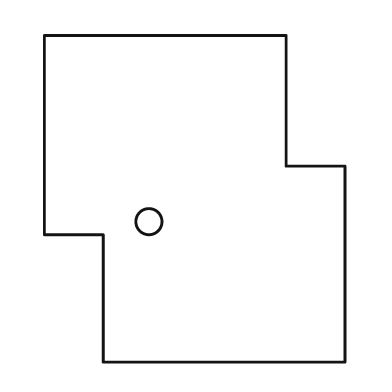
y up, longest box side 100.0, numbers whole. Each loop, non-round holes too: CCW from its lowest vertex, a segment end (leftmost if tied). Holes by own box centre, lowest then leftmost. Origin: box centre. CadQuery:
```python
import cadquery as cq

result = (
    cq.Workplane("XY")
    .moveTo(-28.0, -50.0)
    .lineTo(46.0, -50.0)
    .lineTo(46.0, 10.0)
    .lineTo(28.0, 10.0)
    .lineTo(28.0, 50.0)
    .lineTo(-46.0, 50.0)
    .lineTo(-46.0, -11.0)
    .lineTo(-28.0, -11.0)
    .close()
    .moveTo(-14.0, -7.0)
    .circle(4.0)
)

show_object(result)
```